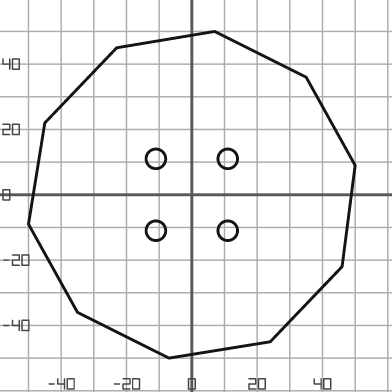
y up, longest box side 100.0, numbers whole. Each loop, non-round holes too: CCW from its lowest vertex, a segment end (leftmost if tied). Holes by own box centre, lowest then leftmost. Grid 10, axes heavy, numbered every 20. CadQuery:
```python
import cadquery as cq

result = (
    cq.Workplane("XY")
    .moveTo(-7.0, -50.0)
    .lineTo(24.0, -45.0)
    .lineTo(46.0, -22.0)
    .lineTo(50.0, 9.0)
    .lineTo(35.0, 36.0)
    .lineTo(7.0, 50.0)
    .lineTo(-23.0, 45.0)
    .lineTo(-45.0, 22.0)
    .lineTo(-50.0, -9.0)
    .lineTo(-35.0, -36.0)
    .close()
    .moveTo(-11.0, -11.0)
    .circle(3.0)
    .moveTo(11.0, -11.0)
    .circle(3.0)
    .moveTo(-11.0, 11.0)
    .circle(3.0)
    .moveTo(11.0, 11.0)
    .circle(3.0)
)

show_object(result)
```